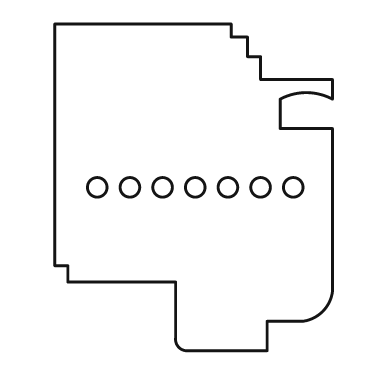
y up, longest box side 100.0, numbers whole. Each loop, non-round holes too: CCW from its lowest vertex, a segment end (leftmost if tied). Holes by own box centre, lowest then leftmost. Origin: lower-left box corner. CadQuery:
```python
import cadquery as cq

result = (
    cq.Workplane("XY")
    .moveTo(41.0, 0.0)
    .lineTo(65.0, 0.0)
    .lineTo(65.0, 9.0)
    .lineTo(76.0, 9.0)
    .threePointArc((82.0, 12.0), (85.0, 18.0))
    .lineTo(85.0, 68.0)
    .lineTo(69.0, 68.0)
    .lineTo(69.0, 77.0)
    .threePointArc((77.0, 79.0), (85.0, 77.0))
    .lineTo(85.0, 83.0)
    .lineTo(63.0, 83.0)
    .lineTo(63.0, 90.0)
    .lineTo(59.0, 90.0)
    .lineTo(59.0, 96.0)
    .lineTo(54.0, 96.0)
    .lineTo(54.0, 100.0)
    .lineTo(0.0, 100.0)
    .lineTo(0.0, 26.0)
    .lineTo(4.0, 26.0)
    .lineTo(4.0, 21.0)
    .lineTo(37.0, 21.0)
    .lineTo(37.0, 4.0)
    .threePointArc((38.0, 1.0), (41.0, 0.0))
    .close()
    .moveTo(13.0, 50.0)
    .circle(3.0)
    .moveTo(23.0, 50.0)
    .circle(3.0)
    .moveTo(33.0, 50.0)
    .circle(3.0)
    .moveTo(43.0, 50.0)
    .circle(3.0)
    .moveTo(53.0, 50.0)
    .circle(3.0)
    .moveTo(63.0, 50.0)
    .circle(3.0)
    .moveTo(73.0, 50.0)
    .circle(3.0)
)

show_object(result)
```